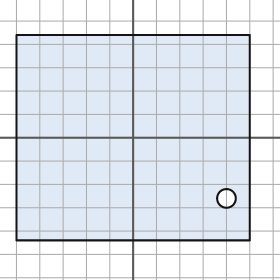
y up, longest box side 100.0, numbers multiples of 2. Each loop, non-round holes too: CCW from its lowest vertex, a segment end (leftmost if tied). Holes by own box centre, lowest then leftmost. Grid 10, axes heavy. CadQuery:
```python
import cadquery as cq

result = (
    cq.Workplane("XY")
    .moveTo(-50.0, -44.0)
    .lineTo(50.0, -44.0)
    .lineTo(50.0, 44.0)
    .lineTo(-50.0, 44.0)
    .close()
    .moveTo(40.0, -26.0)
    .circle(4.0)
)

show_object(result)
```